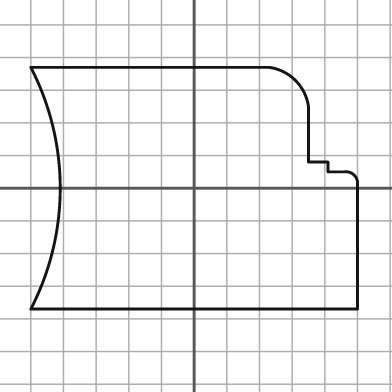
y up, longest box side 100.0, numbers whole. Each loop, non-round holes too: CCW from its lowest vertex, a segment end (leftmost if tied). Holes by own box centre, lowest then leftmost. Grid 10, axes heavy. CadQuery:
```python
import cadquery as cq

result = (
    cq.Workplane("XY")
    .moveTo(-50.0, -37.0)
    .lineTo(50.0, -37.0)
    .lineTo(50.0, 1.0)
    .threePointArc((49.0, 4.0), (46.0, 5.0))
    .lineTo(41.0, 5.0)
    .lineTo(41.0, 8.0)
    .lineTo(35.0, 8.0)
    .lineTo(35.0, 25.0)
    .threePointArc((31.0, 33.0), (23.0, 37.0))
    .lineTo(-50.0, 37.0)
    .threePointArc((-41.0, 0.0), (-50.0, -37.0))
    .close()
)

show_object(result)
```